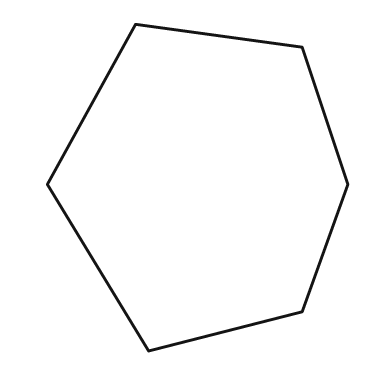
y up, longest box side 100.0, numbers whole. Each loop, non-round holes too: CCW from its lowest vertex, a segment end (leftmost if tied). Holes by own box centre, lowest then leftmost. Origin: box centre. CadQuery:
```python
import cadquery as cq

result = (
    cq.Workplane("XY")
    .moveTo(-15.0, -50.0)
    .lineTo(32.0, -38.0)
    .lineTo(46.0, 1.0)
    .lineTo(32.0, 43.0)
    .lineTo(-19.0, 50.0)
    .lineTo(-46.0, 1.0)
    .close()
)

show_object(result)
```